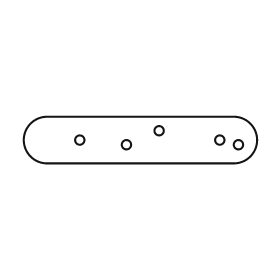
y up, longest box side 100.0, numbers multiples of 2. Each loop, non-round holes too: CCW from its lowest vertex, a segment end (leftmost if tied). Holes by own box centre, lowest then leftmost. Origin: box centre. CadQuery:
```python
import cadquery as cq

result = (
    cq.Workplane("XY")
    .moveTo(-40.0, -10.0)
    .lineTo(40.0, -10.0)
    .threePointArc((50.0, 0.0), (40.0, 10.0))
    .lineTo(-40.0, 10.0)
    .threePointArc((-50.0, 0.0), (-40.0, -10.0))
    .close()
    .moveTo(-6.0, -2.0)
    .circle(2.0)
    .moveTo(42.0, -2.0)
    .circle(2.0)
    .moveTo(-26.0, 0.0)
    .circle(2.0)
    .moveTo(34.0, 0.0)
    .circle(2.0)
    .moveTo(8.0, 4.0)
    .circle(2.0)
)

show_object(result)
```